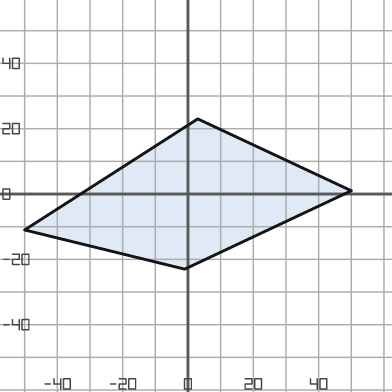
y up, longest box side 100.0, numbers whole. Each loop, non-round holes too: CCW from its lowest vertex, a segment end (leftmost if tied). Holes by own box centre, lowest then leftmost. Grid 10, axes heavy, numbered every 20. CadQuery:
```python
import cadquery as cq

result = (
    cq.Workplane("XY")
    .moveTo(-1.0, -23.0)
    .lineTo(50.0, 1.0)
    .lineTo(3.0, 23.0)
    .lineTo(-50.0, -11.0)
    .close()
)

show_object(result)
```